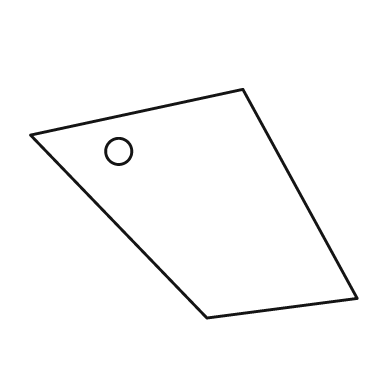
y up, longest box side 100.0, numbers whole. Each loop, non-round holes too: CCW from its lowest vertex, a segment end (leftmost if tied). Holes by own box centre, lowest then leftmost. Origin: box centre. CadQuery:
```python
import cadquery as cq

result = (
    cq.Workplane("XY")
    .moveTo(4.0, -35.0)
    .lineTo(50.0, -29.0)
    .lineTo(15.0, 35.0)
    .lineTo(-50.0, 21.0)
    .close()
    .moveTo(-23.0, 16.0)
    .circle(4.0)
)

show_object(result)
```